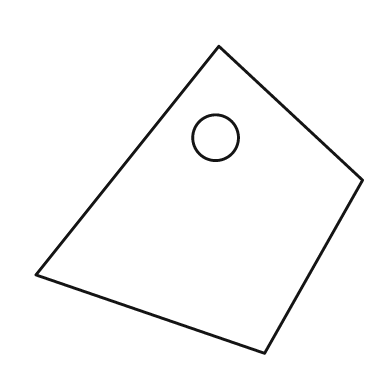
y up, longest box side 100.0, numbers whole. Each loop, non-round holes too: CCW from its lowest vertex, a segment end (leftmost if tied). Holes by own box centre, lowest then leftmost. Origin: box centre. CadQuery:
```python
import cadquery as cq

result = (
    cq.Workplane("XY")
    .moveTo(20.0, -47.0)
    .lineTo(50.0, 6.0)
    .lineTo(6.0, 47.0)
    .lineTo(-50.0, -23.0)
    .close()
    .moveTo(5.0, 19.0)
    .circle(7.0)
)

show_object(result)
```